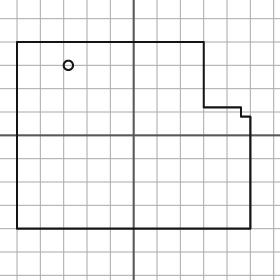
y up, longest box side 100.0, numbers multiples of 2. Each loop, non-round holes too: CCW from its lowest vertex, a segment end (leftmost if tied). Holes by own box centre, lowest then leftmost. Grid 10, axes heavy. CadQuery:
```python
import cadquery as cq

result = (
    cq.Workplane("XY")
    .moveTo(-50.0, -40.0)
    .lineTo(50.0, -40.0)
    .lineTo(50.0, 8.0)
    .lineTo(46.0, 8.0)
    .lineTo(46.0, 12.0)
    .lineTo(30.0, 12.0)
    .lineTo(30.0, 40.0)
    .lineTo(-50.0, 40.0)
    .close()
    .moveTo(-28.0, 30.0)
    .circle(2.0)
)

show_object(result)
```